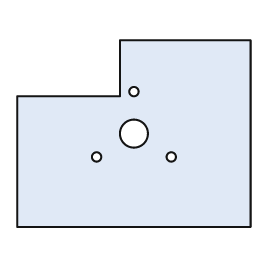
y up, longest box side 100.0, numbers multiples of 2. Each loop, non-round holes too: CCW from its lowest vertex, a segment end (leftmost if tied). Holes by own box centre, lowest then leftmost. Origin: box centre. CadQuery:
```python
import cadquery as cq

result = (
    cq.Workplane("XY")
    .moveTo(-50.0, -40.0)
    .lineTo(50.0, -40.0)
    .lineTo(50.0, 40.0)
    .lineTo(-6.0, 40.0)
    .lineTo(-6.0, 16.0)
    .lineTo(-50.0, 16.0)
    .close()
    .moveTo(-16.0, -10.0)
    .circle(2.0)
    .moveTo(16.0, -10.0)
    .circle(2.0)
    .moveTo(0.0, 0.0)
    .circle(6.0)
    .moveTo(0.0, 18.0)
    .circle(2.0)
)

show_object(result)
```